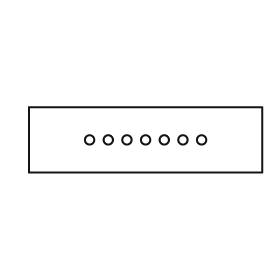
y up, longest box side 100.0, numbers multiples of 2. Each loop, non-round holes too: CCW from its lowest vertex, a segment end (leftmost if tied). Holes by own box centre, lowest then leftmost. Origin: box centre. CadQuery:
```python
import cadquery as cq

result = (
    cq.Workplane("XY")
    .moveTo(-50.0, -14.0)
    .lineTo(50.0, -14.0)
    .lineTo(50.0, 14.0)
    .lineTo(-50.0, 14.0)
    .close()
    .moveTo(-24.0, 0.0)
    .circle(2.0)
    .moveTo(-16.0, 0.0)
    .circle(2.0)
    .moveTo(-8.0, 0.0)
    .circle(2.0)
    .moveTo(0.0, 0.0)
    .circle(2.0)
    .moveTo(8.0, 0.0)
    .circle(2.0)
    .moveTo(16.0, 0.0)
    .circle(2.0)
    .moveTo(24.0, 0.0)
    .circle(2.0)
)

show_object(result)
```